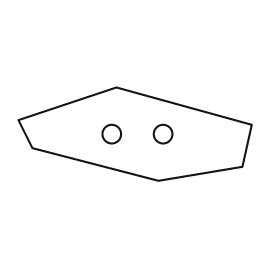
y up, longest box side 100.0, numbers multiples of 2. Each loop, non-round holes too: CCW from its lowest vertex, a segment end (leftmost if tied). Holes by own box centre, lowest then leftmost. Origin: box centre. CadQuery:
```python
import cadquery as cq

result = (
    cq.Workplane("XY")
    .moveTo(10.0, -20.0)
    .lineTo(46.0, -14.0)
    .lineTo(50.0, 4.0)
    .lineTo(-8.0, 20.0)
    .lineTo(-50.0, 6.0)
    .lineTo(-44.0, -6.0)
    .close()
    .moveTo(-10.0, 0.0)
    .circle(4.0)
    .moveTo(12.0, 0.0)
    .circle(4.0)
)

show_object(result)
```